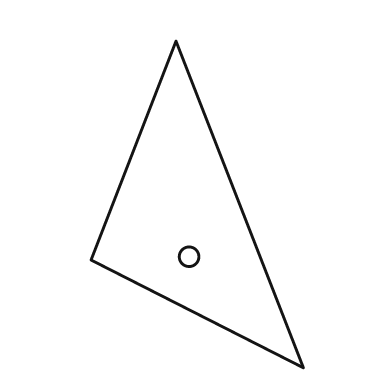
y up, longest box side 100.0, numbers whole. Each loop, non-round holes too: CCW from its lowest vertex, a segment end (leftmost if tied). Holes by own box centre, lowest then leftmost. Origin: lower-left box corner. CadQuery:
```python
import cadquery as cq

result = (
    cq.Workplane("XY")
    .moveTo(65.0, 0.0)
    .lineTo(26.0, 100.0)
    .lineTo(0.0, 33.0)
    .close()
    .moveTo(30.0, 34.0)
    .circle(3.0)
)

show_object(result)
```